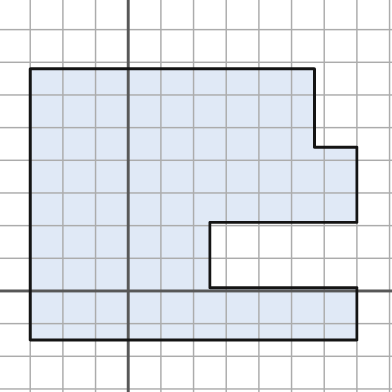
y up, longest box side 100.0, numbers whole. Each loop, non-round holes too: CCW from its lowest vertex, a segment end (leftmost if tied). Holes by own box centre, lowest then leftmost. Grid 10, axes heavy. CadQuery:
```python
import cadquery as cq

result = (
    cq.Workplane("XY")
    .moveTo(-30.0, -15.0)
    .lineTo(70.0, -15.0)
    .lineTo(70.0, 1.0)
    .lineTo(25.0, 1.0)
    .lineTo(25.0, 21.0)
    .lineTo(70.0, 21.0)
    .lineTo(70.0, 44.0)
    .lineTo(57.0, 44.0)
    .lineTo(57.0, 68.0)
    .lineTo(-30.0, 68.0)
    .close()
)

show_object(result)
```